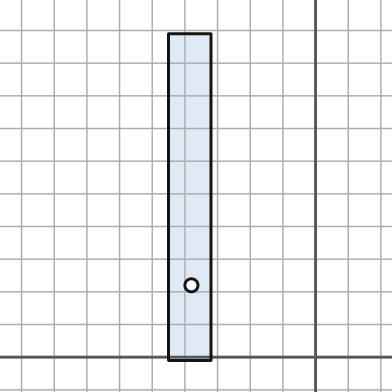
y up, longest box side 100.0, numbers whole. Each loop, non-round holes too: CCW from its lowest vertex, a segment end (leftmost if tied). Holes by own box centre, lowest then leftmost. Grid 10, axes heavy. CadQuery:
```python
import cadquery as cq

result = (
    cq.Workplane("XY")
    .moveTo(-45.0, -1.0)
    .lineTo(-32.0, -1.0)
    .lineTo(-32.0, 99.0)
    .lineTo(-45.0, 99.0)
    .close()
    .moveTo(-38.0, 22.0)
    .circle(2.0)
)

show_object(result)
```